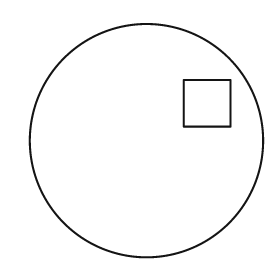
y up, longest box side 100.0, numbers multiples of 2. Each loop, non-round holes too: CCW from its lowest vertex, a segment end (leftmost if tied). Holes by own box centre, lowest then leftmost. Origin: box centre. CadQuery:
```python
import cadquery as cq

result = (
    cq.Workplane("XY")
    .moveTo(0.0, 0.0)
    .circle(50.0)
    .moveTo(16.0, 6.0)
    .lineTo(36.0, 6.0)
    .lineTo(36.0, 26.0)
    .lineTo(16.0, 26.0)
    .close()
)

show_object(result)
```